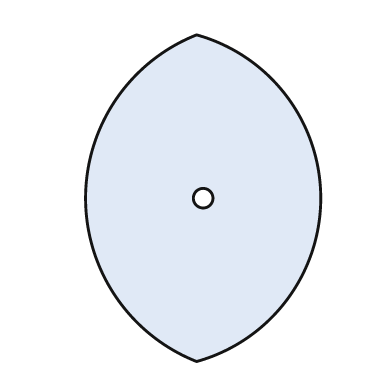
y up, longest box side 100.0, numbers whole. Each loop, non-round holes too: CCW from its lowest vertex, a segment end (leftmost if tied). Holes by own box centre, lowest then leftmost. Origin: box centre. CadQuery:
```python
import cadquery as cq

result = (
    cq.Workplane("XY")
    .moveTo(-2.0, -50.0)
    .threePointArc((36.0, 0.0), (-2.0, 50.0))
    .threePointArc((-36.0, 0.0), (-2.0, -50.0))
    .close()
    .moveTo(0.0, 0.0)
    .circle(3.0)
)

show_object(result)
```